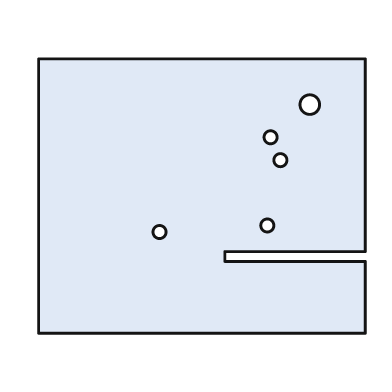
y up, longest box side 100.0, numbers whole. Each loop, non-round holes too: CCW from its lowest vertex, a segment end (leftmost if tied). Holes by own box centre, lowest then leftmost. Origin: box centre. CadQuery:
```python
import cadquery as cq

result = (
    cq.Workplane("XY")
    .moveTo(-50.0, -42.0)
    .lineTo(50.0, -42.0)
    .lineTo(50.0, -20.0)
    .lineTo(7.0, -20.0)
    .lineTo(7.0, -17.0)
    .lineTo(50.0, -17.0)
    .lineTo(50.0, 42.0)
    .lineTo(-50.0, 42.0)
    .close()
    .moveTo(-13.0, -11.0)
    .circle(2.0)
    .moveTo(20.0, -9.0)
    .circle(2.0)
    .moveTo(24.0, 11.0)
    .circle(2.0)
    .moveTo(21.0, 18.0)
    .circle(2.0)
    .moveTo(33.0, 28.0)
    .circle(3.0)
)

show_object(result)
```